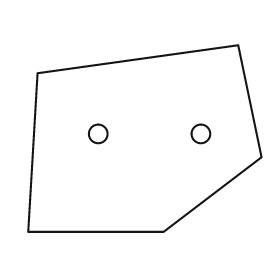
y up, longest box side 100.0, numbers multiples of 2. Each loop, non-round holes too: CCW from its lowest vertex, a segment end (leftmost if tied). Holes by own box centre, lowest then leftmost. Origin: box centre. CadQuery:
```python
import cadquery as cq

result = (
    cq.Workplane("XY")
    .moveTo(-50.0, -40.0)
    .lineTo(8.0, -40.0)
    .lineTo(50.0, -8.0)
    .lineTo(40.0, 40.0)
    .lineTo(-46.0, 28.0)
    .close()
    .moveTo(-20.0, 2.0)
    .circle(4.0)
    .moveTo(24.0, 2.0)
    .circle(4.0)
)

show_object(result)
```